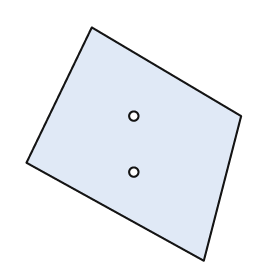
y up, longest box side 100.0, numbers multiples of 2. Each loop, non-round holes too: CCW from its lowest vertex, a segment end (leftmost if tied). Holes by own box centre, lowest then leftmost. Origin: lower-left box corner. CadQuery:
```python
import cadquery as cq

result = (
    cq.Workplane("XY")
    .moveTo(76.0, 0.0)
    .lineTo(92.0, 62.0)
    .lineTo(28.0, 100.0)
    .lineTo(0.0, 42.0)
    .close()
    .moveTo(46.0, 38.0)
    .circle(2.0)
    .moveTo(46.0, 62.0)
    .circle(2.0)
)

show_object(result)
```